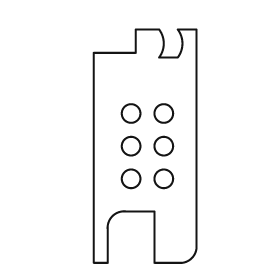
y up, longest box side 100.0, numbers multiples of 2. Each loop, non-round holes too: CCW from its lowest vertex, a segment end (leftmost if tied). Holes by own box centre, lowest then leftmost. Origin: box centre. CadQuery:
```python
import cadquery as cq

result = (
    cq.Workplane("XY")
    .moveTo(-22.0, -50.0)
    .lineTo(-16.0, -50.0)
    .lineTo(-16.0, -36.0)
    .threePointArc((-14.0, -30.0), (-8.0, -28.0))
    .lineTo(4.0, -28.0)
    .lineTo(4.0, -50.0)
    .lineTo(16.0, -50.0)
    .threePointArc((20.0, -48.0), (22.0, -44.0))
    .lineTo(22.0, 50.0)
    .lineTo(14.0, 50.0)
    .threePointArc((16.0, 44.0), (14.0, 38.0))
    .lineTo(6.0, 38.0)
    .threePointArc((8.0, 44.0), (6.0, 50.0))
    .lineTo(-4.0, 50.0)
    .lineTo(-4.0, 40.0)
    .lineTo(-22.0, 40.0)
    .close()
    .moveTo(-6.0, -14.0)
    .circle(4.0)
    .moveTo(8.0, -14.0)
    .circle(4.0)
    .moveTo(-6.0, 0.0)
    .circle(4.0)
    .moveTo(8.0, 0.0)
    .circle(4.0)
    .moveTo(-6.0, 14.0)
    .circle(4.0)
    .moveTo(8.0, 14.0)
    .circle(4.0)
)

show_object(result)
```